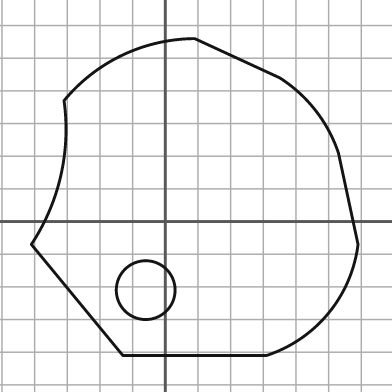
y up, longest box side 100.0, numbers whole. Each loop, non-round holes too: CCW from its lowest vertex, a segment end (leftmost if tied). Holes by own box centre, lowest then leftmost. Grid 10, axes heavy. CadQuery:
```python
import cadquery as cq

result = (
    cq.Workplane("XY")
    .moveTo(-13.0, -41.0)
    .lineTo(31.0, -41.0)
    .threePointArc((50.0, -28.0), (59.0, -7.0))
    .lineTo(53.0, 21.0)
    .threePointArc((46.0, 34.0), (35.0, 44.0))
    .lineTo(9.0, 56.0)
    .threePointArc((-13.0, 51.0), (-31.0, 37.0))
    .threePointArc((-32.0, 14.0), (-41.0, -7.0))
    .close()
    .moveTo(-6.0, -21.0)
    .circle(9.0)
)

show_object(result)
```